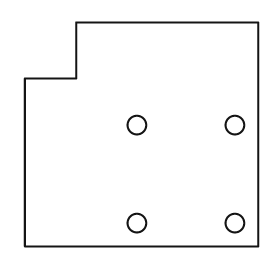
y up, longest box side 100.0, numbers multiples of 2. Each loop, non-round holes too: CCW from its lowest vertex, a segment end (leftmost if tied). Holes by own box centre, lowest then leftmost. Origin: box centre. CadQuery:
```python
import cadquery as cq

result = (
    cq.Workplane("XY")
    .moveTo(-50.0, -48.0)
    .lineTo(50.0, -48.0)
    .lineTo(50.0, 48.0)
    .lineTo(-28.0, 48.0)
    .lineTo(-28.0, 24.0)
    .lineTo(-50.0, 24.0)
    .close()
    .moveTo(-2.0, -38.0)
    .circle(4.0)
    .moveTo(40.0, -38.0)
    .circle(4.0)
    .moveTo(-2.0, 4.0)
    .circle(4.0)
    .moveTo(40.0, 4.0)
    .circle(4.0)
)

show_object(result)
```